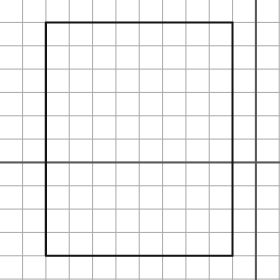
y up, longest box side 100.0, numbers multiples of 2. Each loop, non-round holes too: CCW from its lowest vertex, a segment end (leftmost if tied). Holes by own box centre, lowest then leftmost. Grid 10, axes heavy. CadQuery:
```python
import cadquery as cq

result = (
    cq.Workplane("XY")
    .moveTo(-90.0, -40.0)
    .lineTo(-10.0, -40.0)
    .lineTo(-10.0, 60.0)
    .lineTo(-90.0, 60.0)
    .close()
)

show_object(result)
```